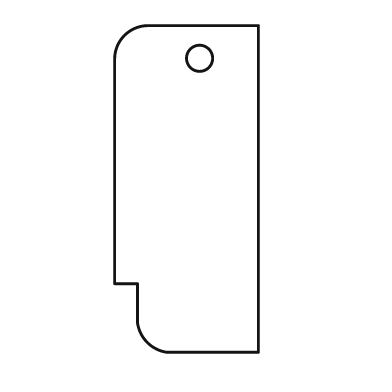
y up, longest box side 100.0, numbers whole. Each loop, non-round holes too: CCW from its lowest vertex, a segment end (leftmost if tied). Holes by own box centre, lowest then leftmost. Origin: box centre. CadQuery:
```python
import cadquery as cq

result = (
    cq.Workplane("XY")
    .moveTo(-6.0, -50.0)
    .lineTo(22.0, -50.0)
    .lineTo(22.0, 50.0)
    .lineTo(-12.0, 50.0)
    .threePointArc((-19.0, 47.0), (-22.0, 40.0))
    .lineTo(-22.0, -29.0)
    .lineTo(-15.0, -29.0)
    .lineTo(-15.0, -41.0)
    .threePointArc((-12.0, -47.0), (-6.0, -50.0))
    .close()
    .moveTo(4.0, 40.0)
    .circle(4.0)
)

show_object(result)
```